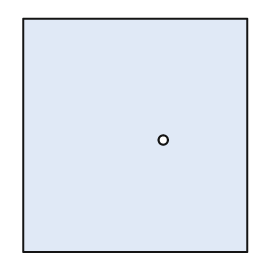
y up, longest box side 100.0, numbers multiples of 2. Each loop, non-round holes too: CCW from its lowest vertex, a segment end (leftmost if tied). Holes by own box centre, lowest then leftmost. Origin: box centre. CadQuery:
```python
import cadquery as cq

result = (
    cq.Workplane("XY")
    .moveTo(-48.0, -50.0)
    .lineTo(48.0, -50.0)
    .lineTo(48.0, 50.0)
    .lineTo(-48.0, 50.0)
    .close()
    .moveTo(12.0, -2.0)
    .circle(2.0)
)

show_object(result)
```